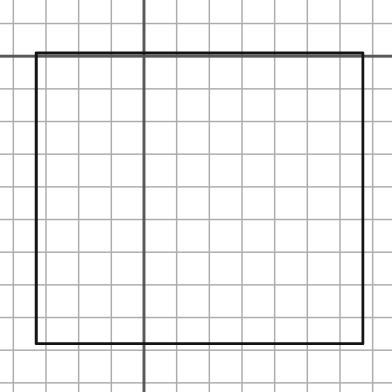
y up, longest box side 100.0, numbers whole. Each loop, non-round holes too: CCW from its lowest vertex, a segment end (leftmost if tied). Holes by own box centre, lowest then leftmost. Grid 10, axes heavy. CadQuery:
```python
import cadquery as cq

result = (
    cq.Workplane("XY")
    .moveTo(-33.0, -88.0)
    .lineTo(67.0, -88.0)
    .lineTo(67.0, 1.0)
    .lineTo(-33.0, 1.0)
    .close()
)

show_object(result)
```